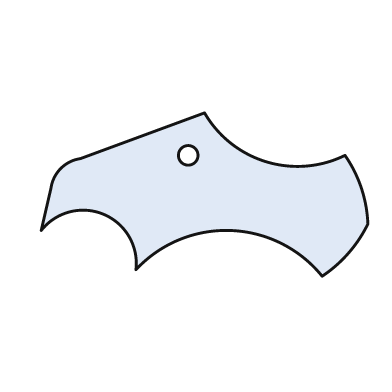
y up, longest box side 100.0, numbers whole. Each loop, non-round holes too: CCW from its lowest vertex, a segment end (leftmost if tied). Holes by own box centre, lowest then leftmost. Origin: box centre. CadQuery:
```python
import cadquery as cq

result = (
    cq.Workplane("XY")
    .moveTo(36.0, -25.0)
    .threePointArc((44.0, -18.0), (50.0, -9.0))
    .threePointArc((48.0, 2.0), (43.0, 12.0))
    .threePointArc((19.0, 10.0), (0.0, 25.0))
    .lineTo(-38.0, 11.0)
    .threePointArc((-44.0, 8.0), (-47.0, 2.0))
    .lineTo(-50.0, -11.0)
    .threePointArc((-31.0, -6.0), (-21.0, -23.0))
    .threePointArc((8.0, -11.0), (36.0, -25.0))
    .close()
    .moveTo(-5.0, 12.0)
    .circle(3.0)
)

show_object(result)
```